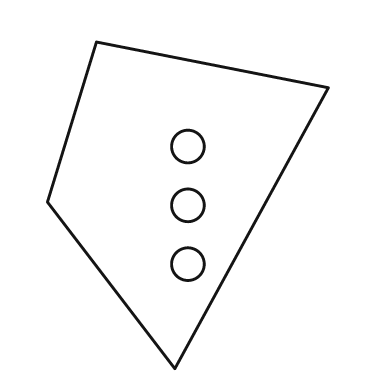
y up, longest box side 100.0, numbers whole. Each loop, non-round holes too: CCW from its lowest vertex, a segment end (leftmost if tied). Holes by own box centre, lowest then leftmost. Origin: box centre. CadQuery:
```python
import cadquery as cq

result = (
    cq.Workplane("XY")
    .moveTo(-4.0, -50.0)
    .lineTo(43.0, 36.0)
    .lineTo(-28.0, 50.0)
    .lineTo(-43.0, 1.0)
    .close()
    .moveTo(0.0, -18.0)
    .circle(5.0)
    .moveTo(0.0, 0.0)
    .circle(5.0)
    .moveTo(0.0, 18.0)
    .circle(5.0)
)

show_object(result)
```